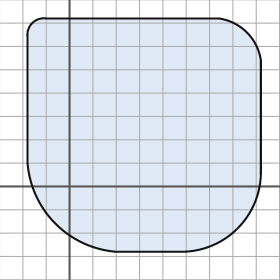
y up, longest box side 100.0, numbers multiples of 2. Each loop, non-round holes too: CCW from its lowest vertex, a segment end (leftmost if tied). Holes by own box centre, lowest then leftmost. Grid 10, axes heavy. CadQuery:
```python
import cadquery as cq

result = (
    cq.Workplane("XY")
    .moveTo(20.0, -28.0)
    .lineTo(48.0, -28.0)
    .threePointArc((72.0, -18.0), (82.0, 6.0))
    .lineTo(82.0, 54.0)
    .threePointArc((76.0, 66.0), (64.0, 72.0))
    .lineTo(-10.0, 72.0)
    .threePointArc((-16.0, 70.0), (-18.0, 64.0))
    .lineTo(-18.0, 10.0)
    .threePointArc((-6.0, -16.0), (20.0, -28.0))
    .close()
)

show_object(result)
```